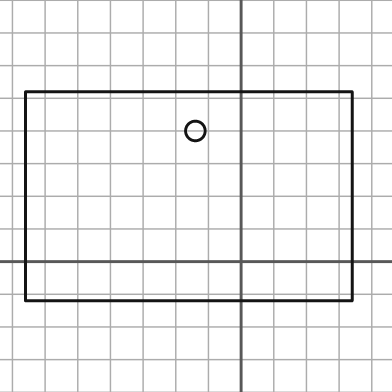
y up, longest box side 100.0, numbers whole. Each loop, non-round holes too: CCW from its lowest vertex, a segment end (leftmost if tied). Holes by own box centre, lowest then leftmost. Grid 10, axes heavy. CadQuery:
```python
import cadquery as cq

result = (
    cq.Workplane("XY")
    .moveTo(-66.0, -12.0)
    .lineTo(34.0, -12.0)
    .lineTo(34.0, 52.0)
    .lineTo(-66.0, 52.0)
    .close()
    .moveTo(-14.0, 40.0)
    .circle(3.0)
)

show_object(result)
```